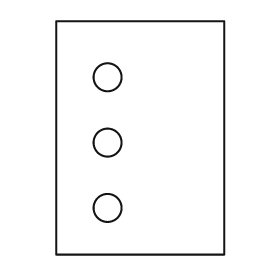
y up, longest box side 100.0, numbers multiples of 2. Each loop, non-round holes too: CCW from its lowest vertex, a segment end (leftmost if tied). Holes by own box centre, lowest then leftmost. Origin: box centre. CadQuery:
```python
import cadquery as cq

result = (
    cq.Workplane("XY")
    .moveTo(-36.0, -50.0)
    .lineTo(36.0, -50.0)
    .lineTo(36.0, 50.0)
    .lineTo(-36.0, 50.0)
    .close()
    .moveTo(-14.0, -30.0)
    .circle(6.0)
    .moveTo(-14.0, -2.0)
    .circle(6.0)
    .moveTo(-14.0, 26.0)
    .circle(6.0)
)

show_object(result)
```